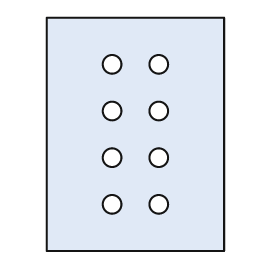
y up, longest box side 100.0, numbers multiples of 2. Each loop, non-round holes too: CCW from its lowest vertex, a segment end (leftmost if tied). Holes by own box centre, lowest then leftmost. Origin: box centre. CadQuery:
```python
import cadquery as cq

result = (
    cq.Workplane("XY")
    .moveTo(-38.0, -50.0)
    .lineTo(38.0, -50.0)
    .lineTo(38.0, 50.0)
    .lineTo(-38.0, 50.0)
    .close()
    .moveTo(-10.0, -30.0)
    .circle(4.0)
    .moveTo(10.0, -30.0)
    .circle(4.0)
    .moveTo(-10.0, -10.0)
    .circle(4.0)
    .moveTo(10.0, -10.0)
    .circle(4.0)
    .moveTo(-10.0, 10.0)
    .circle(4.0)
    .moveTo(10.0, 10.0)
    .circle(4.0)
    .moveTo(-10.0, 30.0)
    .circle(4.0)
    .moveTo(10.0, 30.0)
    .circle(4.0)
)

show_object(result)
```